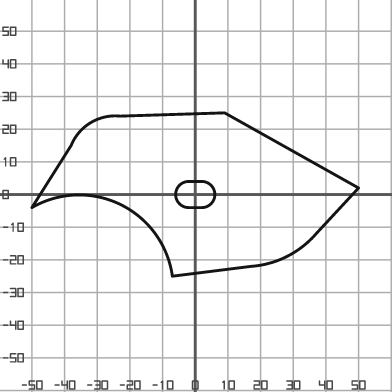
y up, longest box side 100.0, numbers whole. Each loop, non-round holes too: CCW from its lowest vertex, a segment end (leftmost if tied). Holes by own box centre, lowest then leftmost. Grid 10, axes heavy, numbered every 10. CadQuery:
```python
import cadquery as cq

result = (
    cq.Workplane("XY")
    .moveTo(-7.0, -25.0)
    .lineTo(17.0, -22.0)
    .threePointArc((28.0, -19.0), (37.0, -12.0))
    .lineTo(50.0, 2.0)
    .lineTo(9.0, 25.0)
    .lineTo(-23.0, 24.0)
    .threePointArc((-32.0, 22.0), (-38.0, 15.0))
    .lineTo(-50.0, -4.0)
    .threePointArc((-23.0, -3.0), (-7.0, -25.0))
    .close()
    .moveTo(-2.0, -4.0)
    .lineTo(2.0, -4.0)
    .threePointArc((6.0, 0.0), (2.0, 4.0))
    .lineTo(-2.0, 4.0)
    .threePointArc((-6.0, 0.0), (-2.0, -4.0))
    .close()
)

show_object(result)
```